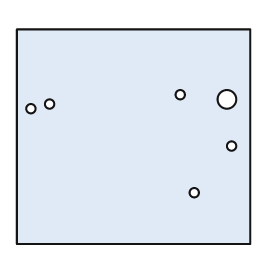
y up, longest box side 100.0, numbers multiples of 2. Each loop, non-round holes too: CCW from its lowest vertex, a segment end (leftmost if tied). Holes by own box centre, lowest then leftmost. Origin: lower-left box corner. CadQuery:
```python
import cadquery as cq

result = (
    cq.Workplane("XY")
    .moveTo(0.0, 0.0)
    .lineTo(100.0, 0.0)
    .lineTo(100.0, 92.0)
    .lineTo(0.0, 92.0)
    .close()
    .moveTo(76.0, 22.0)
    .circle(2.0)
    .moveTo(92.0, 42.0)
    .circle(2.0)
    .moveTo(6.0, 58.0)
    .circle(2.0)
    .moveTo(14.0, 60.0)
    .circle(2.0)
    .moveTo(90.0, 62.0)
    .circle(4.0)
    .moveTo(70.0, 64.0)
    .circle(2.0)
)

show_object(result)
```